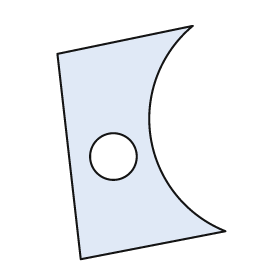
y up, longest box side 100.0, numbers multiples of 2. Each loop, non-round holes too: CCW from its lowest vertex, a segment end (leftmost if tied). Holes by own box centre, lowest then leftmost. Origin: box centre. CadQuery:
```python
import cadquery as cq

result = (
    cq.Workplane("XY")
    .moveTo(-26.0, -50.0)
    .lineTo(36.0, -38.0)
    .threePointArc((4.0, 2.0), (22.0, 50.0))
    .lineTo(-36.0, 38.0)
    .close()
    .moveTo(-12.0, -6.0)
    .circle(10.0)
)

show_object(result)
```